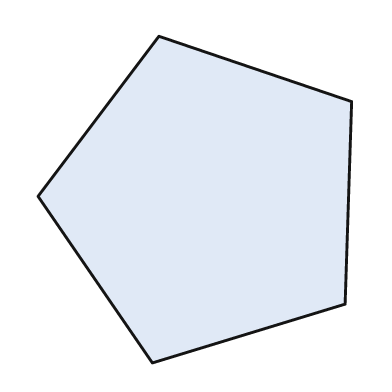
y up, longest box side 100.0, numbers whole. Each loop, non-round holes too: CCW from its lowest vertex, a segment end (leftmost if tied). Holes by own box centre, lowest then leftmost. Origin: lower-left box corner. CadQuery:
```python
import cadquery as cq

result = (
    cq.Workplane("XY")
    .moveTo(35.0, 0.0)
    .lineTo(94.0, 18.0)
    .lineTo(96.0, 80.0)
    .lineTo(37.0, 100.0)
    .lineTo(0.0, 51.0)
    .close()
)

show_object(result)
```